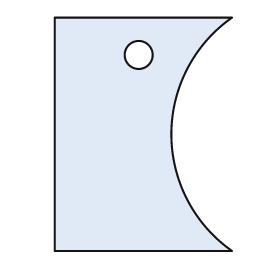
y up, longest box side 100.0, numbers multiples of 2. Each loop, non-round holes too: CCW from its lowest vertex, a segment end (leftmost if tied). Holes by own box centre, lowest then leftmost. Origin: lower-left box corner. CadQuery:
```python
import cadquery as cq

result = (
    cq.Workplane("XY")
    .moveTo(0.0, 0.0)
    .lineTo(76.0, 0.0)
    .threePointArc((50.0, 50.0), (76.0, 100.0))
    .lineTo(0.0, 100.0)
    .close()
    .moveTo(36.0, 84.0)
    .circle(6.0)
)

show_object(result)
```